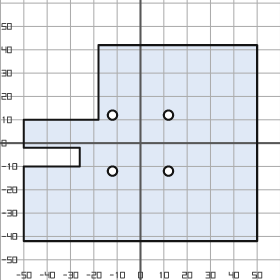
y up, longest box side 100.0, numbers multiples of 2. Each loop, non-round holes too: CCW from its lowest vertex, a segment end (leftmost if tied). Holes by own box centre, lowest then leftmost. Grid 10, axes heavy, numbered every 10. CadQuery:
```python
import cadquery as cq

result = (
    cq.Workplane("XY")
    .moveTo(-50.0, -42.0)
    .lineTo(50.0, -42.0)
    .lineTo(50.0, 42.0)
    .lineTo(-18.0, 42.0)
    .lineTo(-18.0, 10.0)
    .lineTo(-50.0, 10.0)
    .lineTo(-50.0, -2.0)
    .lineTo(-26.0, -2.0)
    .lineTo(-26.0, -10.0)
    .lineTo(-50.0, -10.0)
    .close()
    .moveTo(-12.0, -12.0)
    .circle(2.0)
    .moveTo(12.0, -12.0)
    .circle(2.0)
    .moveTo(-12.0, 12.0)
    .circle(2.0)
    .moveTo(12.0, 12.0)
    .circle(2.0)
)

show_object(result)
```